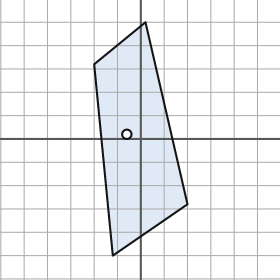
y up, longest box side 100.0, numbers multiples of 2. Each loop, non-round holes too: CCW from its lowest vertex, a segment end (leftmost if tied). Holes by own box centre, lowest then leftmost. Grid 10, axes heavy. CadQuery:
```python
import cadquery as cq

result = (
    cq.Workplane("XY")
    .moveTo(-12.0, -50.0)
    .lineTo(20.0, -28.0)
    .lineTo(2.0, 50.0)
    .lineTo(-20.0, 32.0)
    .close()
    .moveTo(-6.0, 2.0)
    .circle(2.0)
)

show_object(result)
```